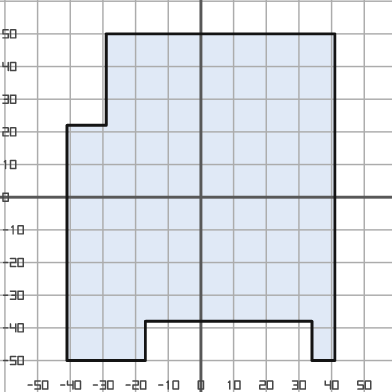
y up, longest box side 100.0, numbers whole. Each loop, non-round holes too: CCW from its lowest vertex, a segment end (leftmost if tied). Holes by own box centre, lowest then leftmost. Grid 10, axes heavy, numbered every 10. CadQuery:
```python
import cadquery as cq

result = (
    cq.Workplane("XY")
    .moveTo(-41.0, -50.0)
    .lineTo(-17.0, -50.0)
    .lineTo(-17.0, -38.0)
    .lineTo(34.0, -38.0)
    .lineTo(34.0, -50.0)
    .lineTo(41.0, -50.0)
    .lineTo(41.0, 50.0)
    .lineTo(-29.0, 50.0)
    .lineTo(-29.0, 22.0)
    .lineTo(-41.0, 22.0)
    .close()
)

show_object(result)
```